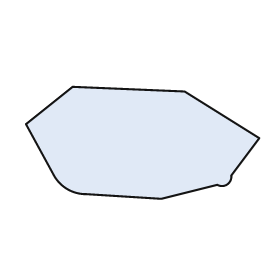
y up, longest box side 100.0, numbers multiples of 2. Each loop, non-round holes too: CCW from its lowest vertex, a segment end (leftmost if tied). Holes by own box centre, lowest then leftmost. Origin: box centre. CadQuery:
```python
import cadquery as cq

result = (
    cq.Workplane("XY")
    .moveTo(8.0, -24.0)
    .lineTo(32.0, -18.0)
    .threePointArc((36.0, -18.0), (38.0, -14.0))
    .lineTo(50.0, 2.0)
    .lineTo(18.0, 22.0)
    .lineTo(-30.0, 24.0)
    .lineTo(-50.0, 8.0)
    .lineTo(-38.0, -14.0)
    .threePointArc((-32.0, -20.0), (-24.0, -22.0))
    .close()
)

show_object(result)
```